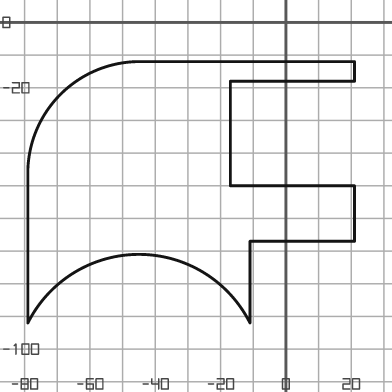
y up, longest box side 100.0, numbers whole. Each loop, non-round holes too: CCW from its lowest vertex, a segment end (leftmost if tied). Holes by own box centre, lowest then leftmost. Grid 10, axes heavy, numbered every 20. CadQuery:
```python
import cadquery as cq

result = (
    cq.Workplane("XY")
    .moveTo(-79.0, -92.0)
    .threePointArc((-45.0, -71.0), (-11.0, -92.0))
    .lineTo(-11.0, -67.0)
    .lineTo(21.0, -67.0)
    .lineTo(21.0, -50.0)
    .lineTo(-17.0, -50.0)
    .lineTo(-17.0, -18.0)
    .lineTo(21.0, -18.0)
    .lineTo(21.0, -12.0)
    .lineTo(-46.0, -12.0)
    .threePointArc((-69.0, -22.0), (-79.0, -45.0))
    .close()
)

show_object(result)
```